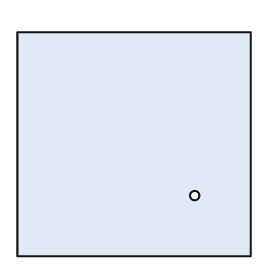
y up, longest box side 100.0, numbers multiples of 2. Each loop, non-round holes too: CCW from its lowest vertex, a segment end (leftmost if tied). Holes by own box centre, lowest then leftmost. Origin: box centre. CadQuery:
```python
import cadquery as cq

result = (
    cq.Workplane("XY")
    .moveTo(-50.0, -48.0)
    .lineTo(50.0, -48.0)
    .lineTo(50.0, 48.0)
    .lineTo(-50.0, 48.0)
    .close()
    .moveTo(26.0, -22.0)
    .circle(2.0)
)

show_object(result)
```